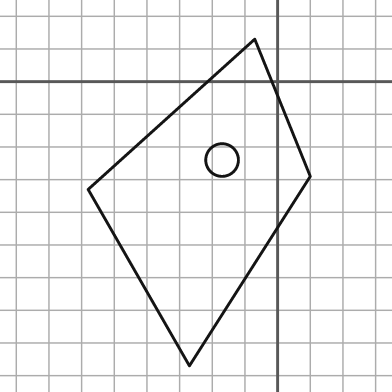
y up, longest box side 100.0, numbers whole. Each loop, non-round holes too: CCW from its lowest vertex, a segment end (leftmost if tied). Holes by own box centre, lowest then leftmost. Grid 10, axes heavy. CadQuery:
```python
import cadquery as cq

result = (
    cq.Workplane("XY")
    .moveTo(-27.0, -87.0)
    .lineTo(10.0, -29.0)
    .lineTo(-7.0, 13.0)
    .lineTo(-58.0, -33.0)
    .close()
    .moveTo(-17.0, -24.0)
    .circle(5.0)
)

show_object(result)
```